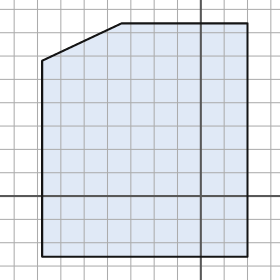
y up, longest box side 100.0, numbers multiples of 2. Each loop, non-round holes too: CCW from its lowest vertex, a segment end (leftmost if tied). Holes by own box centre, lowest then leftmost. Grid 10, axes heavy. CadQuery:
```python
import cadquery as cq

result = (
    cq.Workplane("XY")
    .moveTo(-68.0, -26.0)
    .lineTo(20.0, -26.0)
    .lineTo(20.0, 74.0)
    .lineTo(-34.0, 74.0)
    .lineTo(-68.0, 58.0)
    .close()
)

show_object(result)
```